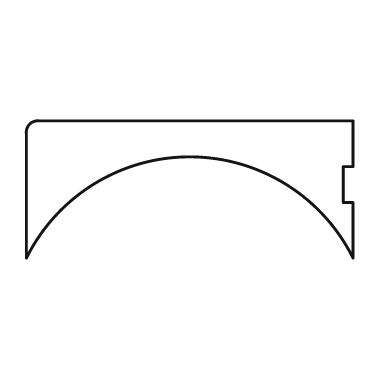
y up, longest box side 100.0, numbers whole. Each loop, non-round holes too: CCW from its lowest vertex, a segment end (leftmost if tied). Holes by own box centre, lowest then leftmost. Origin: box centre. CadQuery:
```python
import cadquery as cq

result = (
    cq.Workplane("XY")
    .moveTo(-50.0, -21.0)
    .threePointArc((0.0, 10.0), (50.0, -21.0))
    .lineTo(50.0, -4.0)
    .lineTo(47.0, -4.0)
    .lineTo(47.0, 7.0)
    .lineTo(50.0, 7.0)
    .lineTo(50.0, 21.0)
    .lineTo(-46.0, 21.0)
    .threePointArc((-49.0, 20.0), (-50.0, 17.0))
    .close()
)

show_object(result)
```